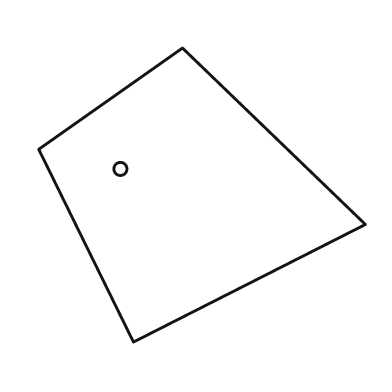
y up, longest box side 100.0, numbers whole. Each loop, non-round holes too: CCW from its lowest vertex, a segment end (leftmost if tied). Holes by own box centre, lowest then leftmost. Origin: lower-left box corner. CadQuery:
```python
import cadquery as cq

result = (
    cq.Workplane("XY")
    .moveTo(29.0, 0.0)
    .lineTo(100.0, 36.0)
    .lineTo(44.0, 90.0)
    .lineTo(0.0, 59.0)
    .close()
    .moveTo(25.0, 53.0)
    .circle(2.0)
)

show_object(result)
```